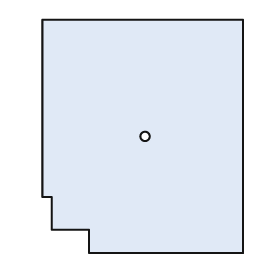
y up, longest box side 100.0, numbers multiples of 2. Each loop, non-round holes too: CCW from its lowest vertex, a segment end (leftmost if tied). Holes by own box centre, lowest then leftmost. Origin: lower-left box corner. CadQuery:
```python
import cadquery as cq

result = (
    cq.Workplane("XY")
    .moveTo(20.0, 0.0)
    .lineTo(86.0, 0.0)
    .lineTo(86.0, 100.0)
    .lineTo(0.0, 100.0)
    .lineTo(0.0, 24.0)
    .lineTo(4.0, 24.0)
    .lineTo(4.0, 10.0)
    .lineTo(20.0, 10.0)
    .close()
    .moveTo(44.0, 50.0)
    .circle(2.0)
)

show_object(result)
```